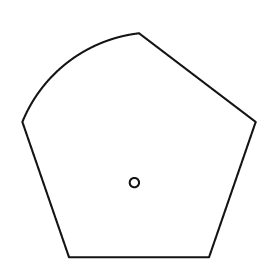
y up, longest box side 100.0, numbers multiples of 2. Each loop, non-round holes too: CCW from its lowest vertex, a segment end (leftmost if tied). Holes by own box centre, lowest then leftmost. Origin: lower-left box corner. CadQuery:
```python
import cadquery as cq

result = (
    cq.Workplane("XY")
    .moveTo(20.0, 0.0)
    .lineTo(80.0, 0.0)
    .lineTo(100.0, 58.0)
    .lineTo(50.0, 96.0)
    .threePointArc((20.0, 84.0), (0.0, 58.0))
    .close()
    .moveTo(48.0, 32.0)
    .circle(2.0)
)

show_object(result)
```